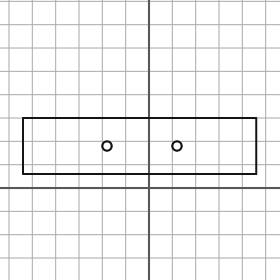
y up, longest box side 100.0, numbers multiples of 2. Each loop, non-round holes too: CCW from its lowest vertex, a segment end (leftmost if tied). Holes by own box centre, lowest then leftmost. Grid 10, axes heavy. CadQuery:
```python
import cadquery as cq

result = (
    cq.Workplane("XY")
    .moveTo(-54.0, 6.0)
    .lineTo(46.0, 6.0)
    .lineTo(46.0, 30.0)
    .lineTo(-54.0, 30.0)
    .close()
    .moveTo(-18.0, 18.0)
    .circle(2.0)
    .moveTo(12.0, 18.0)
    .circle(2.0)
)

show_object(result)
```